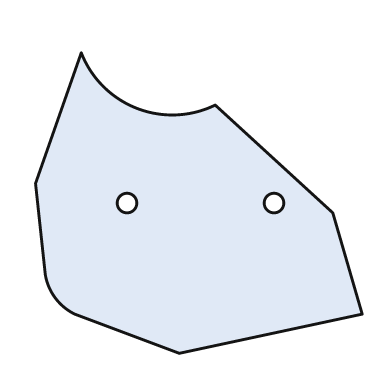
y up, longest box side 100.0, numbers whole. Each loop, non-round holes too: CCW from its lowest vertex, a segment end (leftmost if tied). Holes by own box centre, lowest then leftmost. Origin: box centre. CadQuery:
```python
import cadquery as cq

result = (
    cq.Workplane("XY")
    .moveTo(-6.0, -46.0)
    .lineTo(50.0, -34.0)
    .lineTo(41.0, -3.0)
    .lineTo(5.0, 30.0)
    .threePointArc((-19.0, 29.0), (-36.0, 46.0))
    .lineTo(-50.0, 6.0)
    .lineTo(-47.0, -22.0)
    .threePointArc((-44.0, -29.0), (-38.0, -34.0))
    .close()
    .moveTo(-22.0, 0.0)
    .circle(3.0)
    .moveTo(23.0, 0.0)
    .circle(3.0)
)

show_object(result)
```